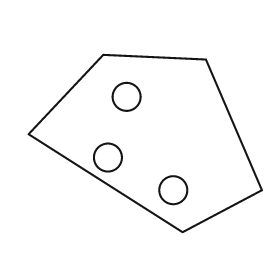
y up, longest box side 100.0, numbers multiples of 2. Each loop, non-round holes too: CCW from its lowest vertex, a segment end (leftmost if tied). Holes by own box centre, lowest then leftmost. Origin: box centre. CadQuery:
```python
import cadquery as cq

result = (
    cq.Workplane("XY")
    .moveTo(16.0, -38.0)
    .lineTo(50.0, -20.0)
    .lineTo(26.0, 36.0)
    .lineTo(-18.0, 38.0)
    .lineTo(-50.0, 4.0)
    .close()
    .moveTo(12.0, -20.0)
    .circle(6.0)
    .moveTo(-16.0, -6.0)
    .circle(6.0)
    .moveTo(-8.0, 20.0)
    .circle(6.0)
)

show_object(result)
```